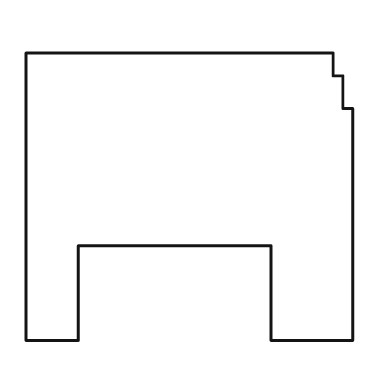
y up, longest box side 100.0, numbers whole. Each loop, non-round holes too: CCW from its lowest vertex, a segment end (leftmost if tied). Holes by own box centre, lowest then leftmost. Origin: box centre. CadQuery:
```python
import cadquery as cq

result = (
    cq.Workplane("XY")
    .moveTo(-50.0, -44.0)
    .lineTo(-34.0, -44.0)
    .lineTo(-34.0, -15.0)
    .lineTo(25.0, -15.0)
    .lineTo(25.0, -44.0)
    .lineTo(50.0, -44.0)
    .lineTo(50.0, 27.0)
    .lineTo(47.0, 27.0)
    .lineTo(47.0, 37.0)
    .lineTo(44.0, 37.0)
    .lineTo(44.0, 44.0)
    .lineTo(-50.0, 44.0)
    .close()
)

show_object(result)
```